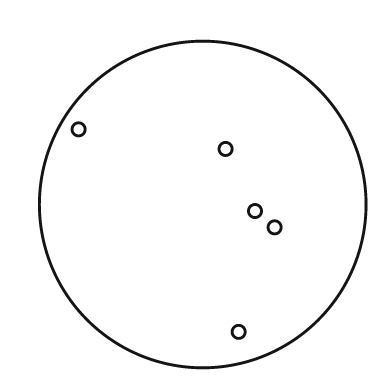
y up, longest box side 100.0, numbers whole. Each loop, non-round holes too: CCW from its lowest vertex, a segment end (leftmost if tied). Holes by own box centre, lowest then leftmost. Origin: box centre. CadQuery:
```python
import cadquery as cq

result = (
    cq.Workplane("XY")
    .moveTo(0.0, 0.0)
    .circle(50.0)
    .moveTo(11.0, -39.0)
    .circle(2.0)
    .moveTo(22.0, -7.0)
    .circle(2.0)
    .moveTo(16.0, -2.0)
    .circle(2.0)
    .moveTo(7.0, 17.0)
    .circle(2.0)
    .moveTo(-38.0, 23.0)
    .circle(2.0)
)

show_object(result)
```